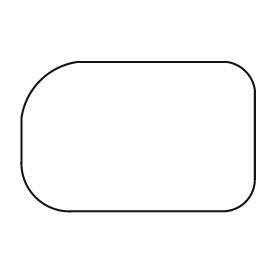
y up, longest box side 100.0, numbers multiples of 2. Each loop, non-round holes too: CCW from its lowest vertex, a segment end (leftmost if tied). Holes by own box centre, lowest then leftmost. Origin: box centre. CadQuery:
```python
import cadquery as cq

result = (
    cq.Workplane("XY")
    .moveTo(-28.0, -32.0)
    .lineTo(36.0, -32.0)
    .threePointArc((46.0, -28.0), (50.0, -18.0))
    .lineTo(50.0, 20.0)
    .threePointArc((46.0, 28.0), (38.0, 32.0))
    .lineTo(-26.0, 32.0)
    .threePointArc((-42.0, 24.0), (-50.0, 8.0))
    .lineTo(-50.0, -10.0)
    .threePointArc((-44.0, -26.0), (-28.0, -32.0))
    .close()
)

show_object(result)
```